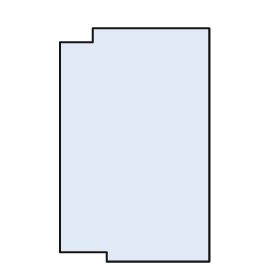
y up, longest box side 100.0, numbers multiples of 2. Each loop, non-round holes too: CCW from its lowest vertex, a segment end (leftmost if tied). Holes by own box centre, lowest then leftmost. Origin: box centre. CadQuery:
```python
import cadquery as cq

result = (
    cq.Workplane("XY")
    .moveTo(-12.0, -50.0)
    .lineTo(32.0, -50.0)
    .lineTo(32.0, 50.0)
    .lineTo(-18.0, 50.0)
    .lineTo(-18.0, 44.0)
    .lineTo(-32.0, 44.0)
    .lineTo(-32.0, -46.0)
    .lineTo(-12.0, -46.0)
    .close()
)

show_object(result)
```